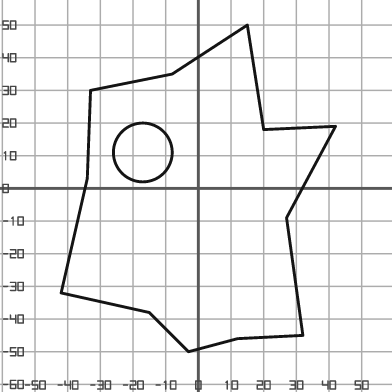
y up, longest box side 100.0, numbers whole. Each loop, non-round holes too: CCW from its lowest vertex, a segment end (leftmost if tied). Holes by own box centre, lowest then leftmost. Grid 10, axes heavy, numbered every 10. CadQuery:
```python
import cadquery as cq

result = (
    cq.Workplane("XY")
    .moveTo(-3.0, -50.0)
    .lineTo(12.0, -46.0)
    .lineTo(32.0, -45.0)
    .lineTo(27.0, -9.0)
    .lineTo(42.0, 19.0)
    .lineTo(20.0, 18.0)
    .lineTo(15.0, 50.0)
    .lineTo(-8.0, 35.0)
    .lineTo(-33.0, 30.0)
    .lineTo(-34.0, 3.0)
    .lineTo(-42.0, -32.0)
    .lineTo(-15.0, -38.0)
    .close()
    .moveTo(-17.0, 11.0)
    .circle(9.0)
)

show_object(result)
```